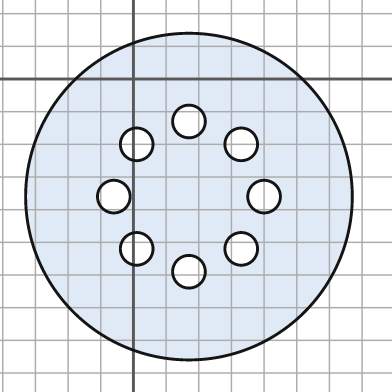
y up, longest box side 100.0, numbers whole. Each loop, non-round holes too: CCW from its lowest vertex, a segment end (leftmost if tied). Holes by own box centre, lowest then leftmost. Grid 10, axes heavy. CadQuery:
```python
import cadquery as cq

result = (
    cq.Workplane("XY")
    .moveTo(17.0, -36.0)
    .circle(50.0)
    .moveTo(17.0, -59.0)
    .circle(5.0)
    .moveTo(1.0, -52.0)
    .circle(5.0)
    .moveTo(33.0, -52.0)
    .circle(5.0)
    .moveTo(-6.0, -36.0)
    .circle(5.0)
    .moveTo(40.0, -36.0)
    .circle(5.0)
    .moveTo(1.0, -20.0)
    .circle(5.0)
    .moveTo(33.0, -20.0)
    .circle(5.0)
    .moveTo(17.0, -13.0)
    .circle(5.0)
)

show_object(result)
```